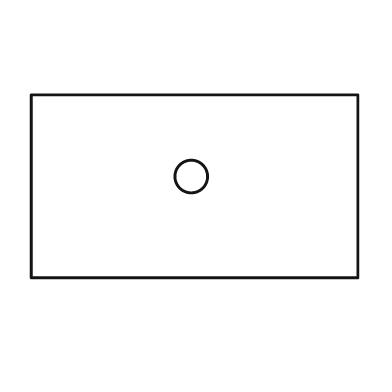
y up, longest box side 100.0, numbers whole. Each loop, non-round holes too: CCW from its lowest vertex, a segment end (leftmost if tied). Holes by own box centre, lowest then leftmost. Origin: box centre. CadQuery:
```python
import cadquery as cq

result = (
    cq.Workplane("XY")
    .moveTo(-50.0, -28.0)
    .lineTo(50.0, -28.0)
    .lineTo(50.0, 28.0)
    .lineTo(-50.0, 28.0)
    .close()
    .moveTo(-1.0, 3.0)
    .circle(5.0)
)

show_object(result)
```